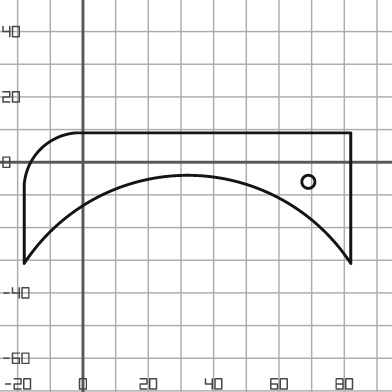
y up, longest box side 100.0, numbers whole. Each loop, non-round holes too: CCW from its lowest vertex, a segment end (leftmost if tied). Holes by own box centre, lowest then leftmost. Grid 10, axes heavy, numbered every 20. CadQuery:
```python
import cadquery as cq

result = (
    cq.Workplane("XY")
    .moveTo(-18.0, -31.0)
    .threePointArc((32.0, -4.0), (82.0, -31.0))
    .lineTo(82.0, 9.0)
    .lineTo(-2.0, 9.0)
    .threePointArc((-13.0, 4.0), (-18.0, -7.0))
    .close()
    .moveTo(69.0, -6.0)
    .circle(2.0)
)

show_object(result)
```